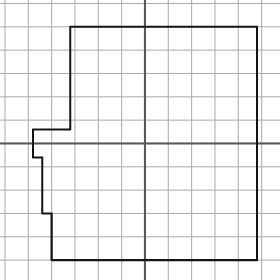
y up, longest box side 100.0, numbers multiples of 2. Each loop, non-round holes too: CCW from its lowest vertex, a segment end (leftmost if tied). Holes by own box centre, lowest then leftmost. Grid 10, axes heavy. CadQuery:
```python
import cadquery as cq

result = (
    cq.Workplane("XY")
    .moveTo(-40.0, -50.0)
    .lineTo(48.0, -50.0)
    .lineTo(48.0, 50.0)
    .lineTo(-32.0, 50.0)
    .lineTo(-32.0, 6.0)
    .lineTo(-48.0, 6.0)
    .lineTo(-48.0, -6.0)
    .lineTo(-44.0, -6.0)
    .lineTo(-44.0, -30.0)
    .lineTo(-40.0, -30.0)
    .close()
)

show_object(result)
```